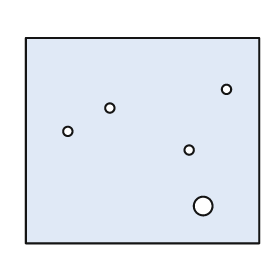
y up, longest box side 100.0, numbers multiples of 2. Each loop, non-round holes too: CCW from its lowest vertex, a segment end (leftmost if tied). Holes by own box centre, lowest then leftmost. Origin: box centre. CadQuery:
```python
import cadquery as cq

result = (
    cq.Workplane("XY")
    .moveTo(-50.0, -44.0)
    .lineTo(50.0, -44.0)
    .lineTo(50.0, 44.0)
    .lineTo(-50.0, 44.0)
    .close()
    .moveTo(26.0, -28.0)
    .circle(4.0)
    .moveTo(20.0, -4.0)
    .circle(2.0)
    .moveTo(-32.0, 4.0)
    .circle(2.0)
    .moveTo(-14.0, 14.0)
    .circle(2.0)
    .moveTo(36.0, 22.0)
    .circle(2.0)
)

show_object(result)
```